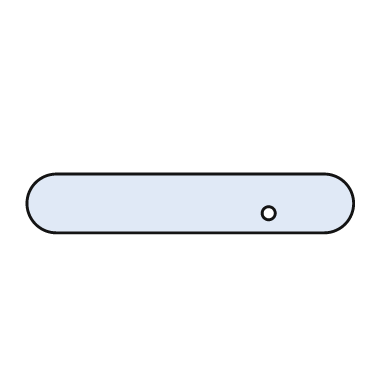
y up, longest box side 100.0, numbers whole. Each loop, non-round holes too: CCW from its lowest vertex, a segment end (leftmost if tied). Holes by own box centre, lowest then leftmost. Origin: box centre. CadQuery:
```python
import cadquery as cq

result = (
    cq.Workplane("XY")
    .moveTo(-41.0, -9.0)
    .lineTo(41.0, -9.0)
    .threePointArc((50.0, 0.0), (41.0, 9.0))
    .lineTo(-41.0, 9.0)
    .threePointArc((-50.0, 0.0), (-41.0, -9.0))
    .close()
    .moveTo(24.0, -3.0)
    .circle(2.0)
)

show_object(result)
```